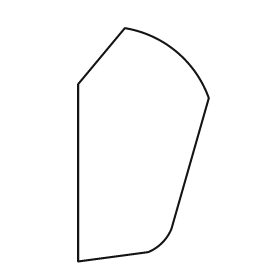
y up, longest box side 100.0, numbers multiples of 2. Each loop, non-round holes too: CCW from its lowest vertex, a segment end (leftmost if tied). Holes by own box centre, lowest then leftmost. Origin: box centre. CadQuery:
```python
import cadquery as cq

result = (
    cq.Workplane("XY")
    .moveTo(-28.0, -50.0)
    .lineTo(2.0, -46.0)
    .threePointArc((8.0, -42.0), (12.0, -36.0))
    .lineTo(28.0, 20.0)
    .threePointArc((14.0, 40.0), (-8.0, 50.0))
    .lineTo(-28.0, 26.0)
    .close()
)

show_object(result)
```